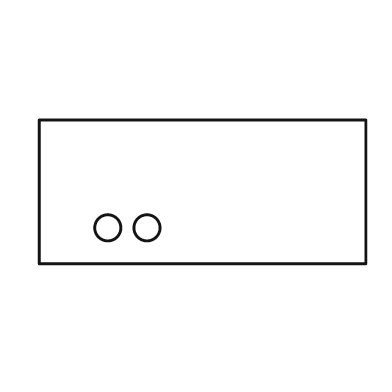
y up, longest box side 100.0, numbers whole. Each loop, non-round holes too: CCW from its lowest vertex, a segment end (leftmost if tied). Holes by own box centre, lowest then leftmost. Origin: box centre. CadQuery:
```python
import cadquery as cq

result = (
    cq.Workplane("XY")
    .moveTo(-50.0, -22.0)
    .lineTo(50.0, -22.0)
    .lineTo(50.0, 22.0)
    .lineTo(-50.0, 22.0)
    .close()
    .moveTo(-29.0, -11.0)
    .circle(4.0)
    .moveTo(-17.0, -11.0)
    .circle(4.0)
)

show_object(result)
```